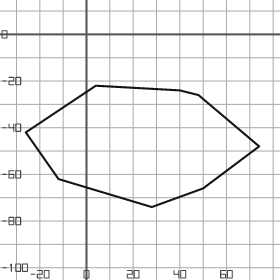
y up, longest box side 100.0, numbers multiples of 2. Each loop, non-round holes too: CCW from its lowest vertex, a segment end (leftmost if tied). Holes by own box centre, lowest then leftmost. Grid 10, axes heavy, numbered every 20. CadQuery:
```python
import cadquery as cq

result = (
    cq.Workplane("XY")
    .moveTo(28.0, -74.0)
    .lineTo(50.0, -66.0)
    .lineTo(74.0, -48.0)
    .lineTo(48.0, -26.0)
    .lineTo(40.0, -24.0)
    .lineTo(4.0, -22.0)
    .lineTo(-26.0, -42.0)
    .lineTo(-12.0, -62.0)
    .close()
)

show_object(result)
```